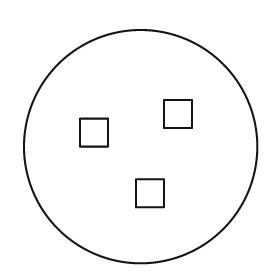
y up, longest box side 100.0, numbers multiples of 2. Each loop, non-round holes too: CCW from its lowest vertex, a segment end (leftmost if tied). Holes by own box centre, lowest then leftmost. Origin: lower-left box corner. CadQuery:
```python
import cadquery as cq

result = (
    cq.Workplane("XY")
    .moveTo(50.0, 50.0)
    .circle(50.0)
    .moveTo(48.0, 24.0)
    .lineTo(60.0, 24.0)
    .lineTo(60.0, 36.0)
    .lineTo(48.0, 36.0)
    .close()
    .moveTo(24.0, 50.0)
    .lineTo(36.0, 50.0)
    .lineTo(36.0, 62.0)
    .lineTo(24.0, 62.0)
    .close()
    .moveTo(60.0, 58.0)
    .lineTo(72.0, 58.0)
    .lineTo(72.0, 70.0)
    .lineTo(60.0, 70.0)
    .close()
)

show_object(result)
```